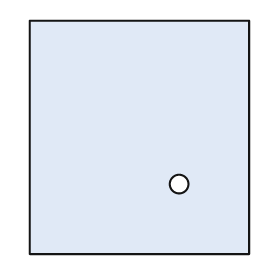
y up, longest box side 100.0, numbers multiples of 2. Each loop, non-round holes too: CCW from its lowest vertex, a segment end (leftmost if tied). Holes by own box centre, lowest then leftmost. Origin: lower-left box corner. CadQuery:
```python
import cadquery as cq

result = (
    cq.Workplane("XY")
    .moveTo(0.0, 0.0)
    .lineTo(94.0, 0.0)
    .lineTo(94.0, 100.0)
    .lineTo(0.0, 100.0)
    .close()
    .moveTo(64.0, 30.0)
    .circle(4.0)
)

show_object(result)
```